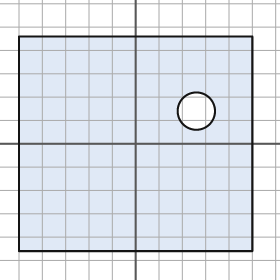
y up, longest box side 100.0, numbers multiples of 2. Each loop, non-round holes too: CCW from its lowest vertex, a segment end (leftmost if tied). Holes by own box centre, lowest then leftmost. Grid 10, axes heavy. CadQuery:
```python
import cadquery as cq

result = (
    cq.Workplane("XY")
    .moveTo(-50.0, -46.0)
    .lineTo(50.0, -46.0)
    .lineTo(50.0, 46.0)
    .lineTo(-50.0, 46.0)
    .close()
    .moveTo(26.0, 14.0)
    .circle(8.0)
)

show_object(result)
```